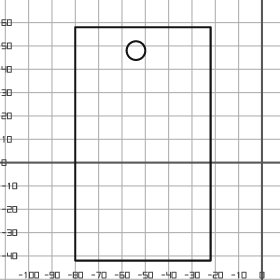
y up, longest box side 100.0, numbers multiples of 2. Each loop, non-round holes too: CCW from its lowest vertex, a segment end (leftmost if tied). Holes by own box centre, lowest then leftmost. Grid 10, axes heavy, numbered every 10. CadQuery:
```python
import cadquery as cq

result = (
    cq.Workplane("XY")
    .moveTo(-80.0, -42.0)
    .lineTo(-22.0, -42.0)
    .lineTo(-22.0, 58.0)
    .lineTo(-80.0, 58.0)
    .close()
    .moveTo(-54.0, 48.0)
    .circle(4.0)
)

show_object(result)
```